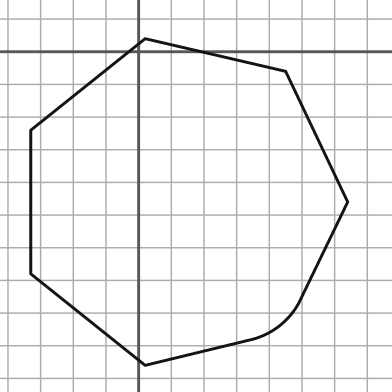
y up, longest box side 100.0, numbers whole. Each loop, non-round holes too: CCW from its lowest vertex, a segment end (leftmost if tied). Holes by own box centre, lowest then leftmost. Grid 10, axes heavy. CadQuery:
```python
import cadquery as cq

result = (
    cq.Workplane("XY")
    .moveTo(2.0, -96.0)
    .lineTo(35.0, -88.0)
    .threePointArc((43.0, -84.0), (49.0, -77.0))
    .lineTo(64.0, -46.0)
    .lineTo(45.0, -6.0)
    .lineTo(2.0, 4.0)
    .lineTo(-33.0, -24.0)
    .lineTo(-33.0, -68.0)
    .close()
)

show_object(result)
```